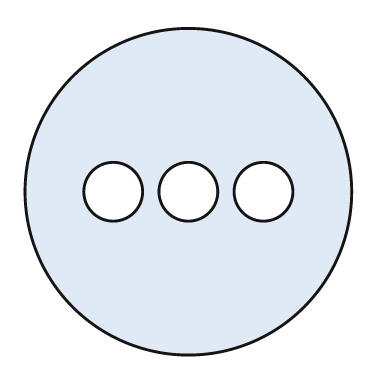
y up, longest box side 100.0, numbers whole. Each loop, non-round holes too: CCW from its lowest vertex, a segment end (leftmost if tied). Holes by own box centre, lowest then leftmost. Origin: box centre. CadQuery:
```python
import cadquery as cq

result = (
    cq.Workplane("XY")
    .moveTo(0.0, 0.0)
    .circle(50.0)
    .moveTo(-23.0, 0.0)
    .circle(9.0)
    .moveTo(0.0, 0.0)
    .circle(9.0)
    .moveTo(23.0, 0.0)
    .circle(9.0)
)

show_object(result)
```